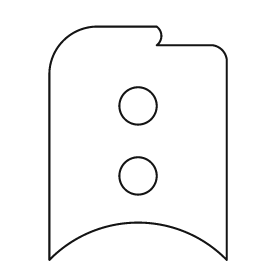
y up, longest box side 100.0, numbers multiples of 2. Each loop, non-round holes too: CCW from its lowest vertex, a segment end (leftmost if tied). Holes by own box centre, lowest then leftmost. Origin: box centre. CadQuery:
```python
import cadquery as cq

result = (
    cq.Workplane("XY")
    .moveTo(-38.0, -50.0)
    .threePointArc((0.0, -34.0), (38.0, -50.0))
    .lineTo(38.0, 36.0)
    .threePointArc((36.0, 40.0), (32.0, 42.0))
    .lineTo(8.0, 42.0)
    .threePointArc((10.0, 46.0), (8.0, 50.0))
    .lineTo(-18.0, 50.0)
    .threePointArc((-32.0, 44.0), (-38.0, 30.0))
    .close()
    .moveTo(0.0, -14.0)
    .circle(8.0)
    .moveTo(0.0, 16.0)
    .circle(8.0)
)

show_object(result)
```